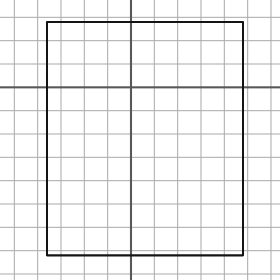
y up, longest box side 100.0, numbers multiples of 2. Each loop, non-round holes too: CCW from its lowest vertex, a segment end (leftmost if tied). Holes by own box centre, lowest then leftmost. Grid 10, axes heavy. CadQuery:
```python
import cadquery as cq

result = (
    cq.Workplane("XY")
    .moveTo(-36.0, -72.0)
    .lineTo(48.0, -72.0)
    .lineTo(48.0, 28.0)
    .lineTo(-36.0, 28.0)
    .close()
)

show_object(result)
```